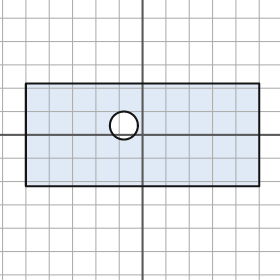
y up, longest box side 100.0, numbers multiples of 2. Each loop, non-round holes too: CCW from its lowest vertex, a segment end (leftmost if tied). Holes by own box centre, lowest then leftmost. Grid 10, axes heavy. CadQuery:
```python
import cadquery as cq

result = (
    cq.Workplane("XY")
    .moveTo(-50.0, -22.0)
    .lineTo(50.0, -22.0)
    .lineTo(50.0, 22.0)
    .lineTo(-50.0, 22.0)
    .close()
    .moveTo(-8.0, 4.0)
    .circle(6.0)
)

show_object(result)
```